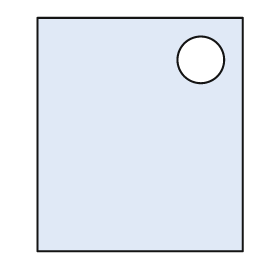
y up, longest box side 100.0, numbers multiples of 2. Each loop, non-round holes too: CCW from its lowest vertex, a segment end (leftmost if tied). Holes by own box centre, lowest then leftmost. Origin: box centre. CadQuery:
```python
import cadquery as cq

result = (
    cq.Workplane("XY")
    .moveTo(-44.0, -50.0)
    .lineTo(44.0, -50.0)
    .lineTo(44.0, 50.0)
    .lineTo(-44.0, 50.0)
    .close()
    .moveTo(26.0, 32.0)
    .circle(10.0)
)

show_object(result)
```